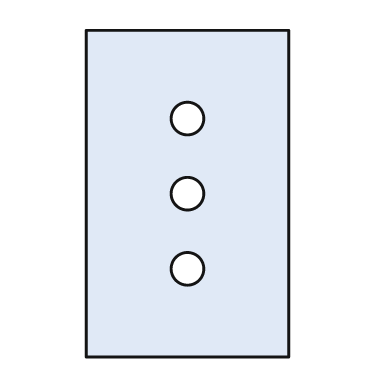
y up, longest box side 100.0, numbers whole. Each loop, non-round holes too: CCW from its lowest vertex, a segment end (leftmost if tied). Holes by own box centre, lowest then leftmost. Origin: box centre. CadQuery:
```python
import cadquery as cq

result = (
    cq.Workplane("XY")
    .moveTo(-31.0, -50.0)
    .lineTo(31.0, -50.0)
    .lineTo(31.0, 50.0)
    .lineTo(-31.0, 50.0)
    .close()
    .moveTo(0.0, -23.0)
    .circle(5.0)
    .moveTo(0.0, 0.0)
    .circle(5.0)
    .moveTo(0.0, 23.0)
    .circle(5.0)
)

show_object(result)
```